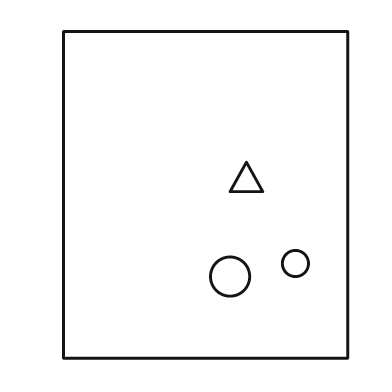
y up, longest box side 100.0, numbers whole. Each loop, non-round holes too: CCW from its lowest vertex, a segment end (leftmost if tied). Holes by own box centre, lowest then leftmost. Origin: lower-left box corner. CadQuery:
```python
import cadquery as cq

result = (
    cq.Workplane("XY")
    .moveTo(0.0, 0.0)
    .lineTo(87.0, 0.0)
    .lineTo(87.0, 100.0)
    .lineTo(0.0, 100.0)
    .close()
    .moveTo(51.0, 25.0)
    .circle(6.0)
    .moveTo(71.0, 29.0)
    .circle(4.0)
    .moveTo(51.0, 51.0)
    .lineTo(61.0, 51.0)
    .lineTo(56.0, 60.0)
    .close()
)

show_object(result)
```